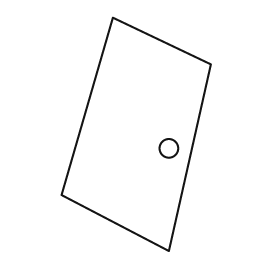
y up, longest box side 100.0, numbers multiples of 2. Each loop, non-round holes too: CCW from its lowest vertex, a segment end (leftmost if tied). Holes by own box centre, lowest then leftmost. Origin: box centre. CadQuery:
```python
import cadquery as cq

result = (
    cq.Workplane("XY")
    .moveTo(14.0, -50.0)
    .lineTo(32.0, 30.0)
    .lineTo(-10.0, 50.0)
    .lineTo(-32.0, -26.0)
    .close()
    .moveTo(14.0, -6.0)
    .circle(4.0)
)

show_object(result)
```